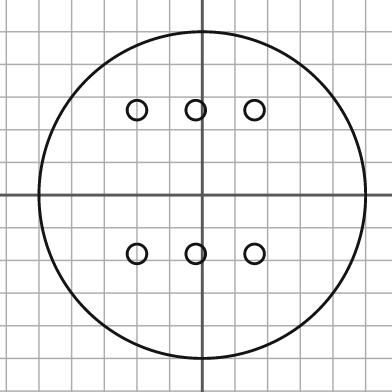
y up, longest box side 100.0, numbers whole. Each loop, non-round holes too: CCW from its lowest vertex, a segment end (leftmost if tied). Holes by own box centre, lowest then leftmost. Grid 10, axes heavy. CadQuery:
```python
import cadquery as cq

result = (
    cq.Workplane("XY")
    .moveTo(0.0, 0.0)
    .circle(50.0)
    .moveTo(-20.0, -18.0)
    .circle(3.0)
    .moveTo(-2.0, -18.0)
    .circle(3.0)
    .moveTo(16.0, -18.0)
    .circle(3.0)
    .moveTo(-20.0, 26.0)
    .circle(3.0)
    .moveTo(-2.0, 26.0)
    .circle(3.0)
    .moveTo(16.0, 26.0)
    .circle(3.0)
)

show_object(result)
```